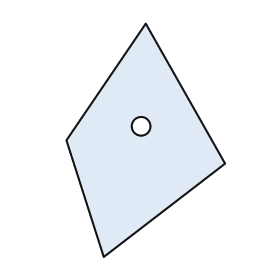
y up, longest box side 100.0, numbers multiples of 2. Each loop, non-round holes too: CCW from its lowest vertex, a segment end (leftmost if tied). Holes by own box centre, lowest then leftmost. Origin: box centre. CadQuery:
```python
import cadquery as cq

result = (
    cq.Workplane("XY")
    .moveTo(-18.0, -50.0)
    .lineTo(34.0, -10.0)
    .lineTo(0.0, 50.0)
    .lineTo(-34.0, 0.0)
    .close()
    .moveTo(-2.0, 6.0)
    .circle(4.0)
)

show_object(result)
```